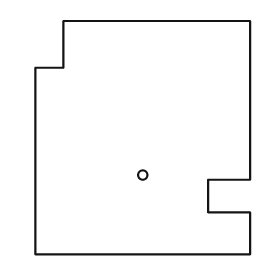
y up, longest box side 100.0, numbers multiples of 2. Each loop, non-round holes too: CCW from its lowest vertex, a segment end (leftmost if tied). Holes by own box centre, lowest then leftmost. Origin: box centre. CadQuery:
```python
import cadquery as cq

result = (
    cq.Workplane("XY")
    .moveTo(-46.0, -50.0)
    .lineTo(46.0, -50.0)
    .lineTo(46.0, -32.0)
    .lineTo(28.0, -32.0)
    .lineTo(28.0, -18.0)
    .lineTo(46.0, -18.0)
    .lineTo(46.0, 50.0)
    .lineTo(-34.0, 50.0)
    .lineTo(-34.0, 30.0)
    .lineTo(-46.0, 30.0)
    .close()
    .moveTo(0.0, -16.0)
    .circle(2.0)
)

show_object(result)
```